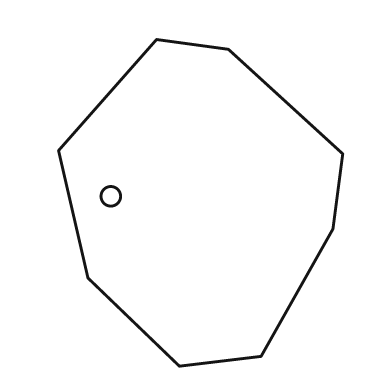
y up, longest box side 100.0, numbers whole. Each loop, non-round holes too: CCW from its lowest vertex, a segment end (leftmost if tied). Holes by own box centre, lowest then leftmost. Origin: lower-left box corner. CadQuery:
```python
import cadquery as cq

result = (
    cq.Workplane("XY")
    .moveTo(37.0, 0.0)
    .lineTo(62.0, 3.0)
    .lineTo(84.0, 42.0)
    .lineTo(87.0, 65.0)
    .lineTo(52.0, 97.0)
    .lineTo(30.0, 100.0)
    .lineTo(0.0, 66.0)
    .lineTo(9.0, 27.0)
    .close()
    .moveTo(16.0, 52.0)
    .circle(3.0)
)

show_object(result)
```